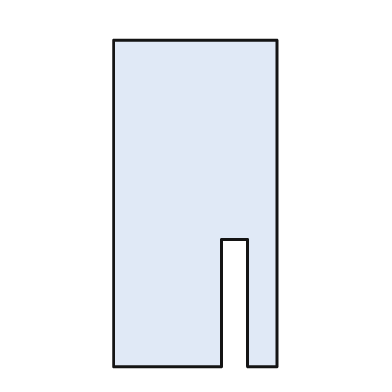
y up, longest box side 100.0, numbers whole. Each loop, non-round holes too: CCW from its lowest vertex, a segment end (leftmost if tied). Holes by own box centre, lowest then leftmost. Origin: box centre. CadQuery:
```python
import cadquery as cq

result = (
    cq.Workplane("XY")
    .moveTo(-25.0, -50.0)
    .lineTo(8.0, -50.0)
    .lineTo(8.0, -11.0)
    .lineTo(16.0, -11.0)
    .lineTo(16.0, -50.0)
    .lineTo(25.0, -50.0)
    .lineTo(25.0, 50.0)
    .lineTo(-25.0, 50.0)
    .close()
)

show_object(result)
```